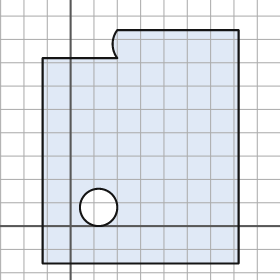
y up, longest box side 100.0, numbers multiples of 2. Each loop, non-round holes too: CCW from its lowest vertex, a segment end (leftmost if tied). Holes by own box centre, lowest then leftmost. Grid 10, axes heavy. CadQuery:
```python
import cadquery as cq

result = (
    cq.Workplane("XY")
    .moveTo(-12.0, -16.0)
    .lineTo(72.0, -16.0)
    .lineTo(72.0, 84.0)
    .lineTo(20.0, 84.0)
    .threePointArc((18.0, 78.0), (20.0, 72.0))
    .lineTo(-12.0, 72.0)
    .close()
    .moveTo(12.0, 8.0)
    .circle(8.0)
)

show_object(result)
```